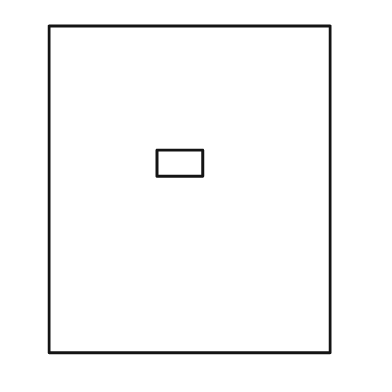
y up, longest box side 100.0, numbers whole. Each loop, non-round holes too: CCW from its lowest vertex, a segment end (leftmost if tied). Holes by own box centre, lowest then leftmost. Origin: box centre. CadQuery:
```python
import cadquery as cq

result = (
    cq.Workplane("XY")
    .moveTo(-43.0, -50.0)
    .lineTo(43.0, -50.0)
    .lineTo(43.0, 50.0)
    .lineTo(-43.0, 50.0)
    .close()
    .moveTo(-10.0, 4.0)
    .lineTo(4.0, 4.0)
    .lineTo(4.0, 12.0)
    .lineTo(-10.0, 12.0)
    .close()
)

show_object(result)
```